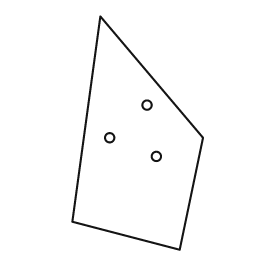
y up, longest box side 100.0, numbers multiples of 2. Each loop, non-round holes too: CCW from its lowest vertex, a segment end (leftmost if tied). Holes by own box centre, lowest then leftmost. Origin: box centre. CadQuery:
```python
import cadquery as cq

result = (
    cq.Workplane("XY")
    .moveTo(18.0, -50.0)
    .lineTo(28.0, -2.0)
    .lineTo(-16.0, 50.0)
    .lineTo(-28.0, -38.0)
    .close()
    .moveTo(8.0, -10.0)
    .circle(2.0)
    .moveTo(-12.0, -2.0)
    .circle(2.0)
    .moveTo(4.0, 12.0)
    .circle(2.0)
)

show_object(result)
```